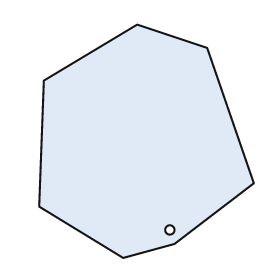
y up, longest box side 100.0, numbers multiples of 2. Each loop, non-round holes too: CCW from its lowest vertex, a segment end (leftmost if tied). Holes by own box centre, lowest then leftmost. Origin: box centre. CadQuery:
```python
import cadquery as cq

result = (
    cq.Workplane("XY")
    .moveTo(-10.0, -50.0)
    .lineTo(12.0, -44.0)
    .lineTo(46.0, -18.0)
    .lineTo(26.0, 40.0)
    .lineTo(-4.0, 50.0)
    .lineTo(-44.0, 26.0)
    .lineTo(-46.0, -28.0)
    .close()
    .moveTo(10.0, -38.0)
    .circle(2.0)
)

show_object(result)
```